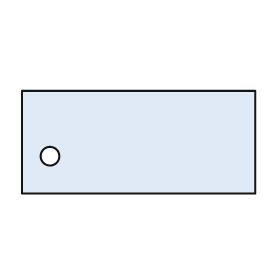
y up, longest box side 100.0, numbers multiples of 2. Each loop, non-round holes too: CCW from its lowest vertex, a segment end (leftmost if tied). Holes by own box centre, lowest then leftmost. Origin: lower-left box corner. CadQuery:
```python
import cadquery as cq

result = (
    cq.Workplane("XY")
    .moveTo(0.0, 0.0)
    .lineTo(100.0, 0.0)
    .lineTo(100.0, 44.0)
    .lineTo(0.0, 44.0)
    .close()
    .moveTo(12.0, 16.0)
    .circle(4.0)
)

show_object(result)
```